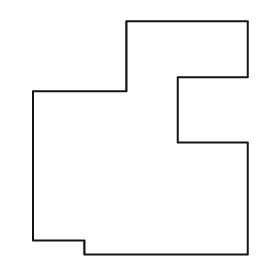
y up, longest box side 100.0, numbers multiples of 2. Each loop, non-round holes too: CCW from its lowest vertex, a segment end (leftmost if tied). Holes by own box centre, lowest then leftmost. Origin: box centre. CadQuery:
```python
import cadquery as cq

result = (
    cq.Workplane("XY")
    .moveTo(-24.0, -50.0)
    .lineTo(46.0, -50.0)
    .lineTo(46.0, -2.0)
    .lineTo(16.0, -2.0)
    .lineTo(16.0, 26.0)
    .lineTo(46.0, 26.0)
    .lineTo(46.0, 50.0)
    .lineTo(-6.0, 50.0)
    .lineTo(-6.0, 20.0)
    .lineTo(-46.0, 20.0)
    .lineTo(-46.0, -44.0)
    .lineTo(-24.0, -44.0)
    .close()
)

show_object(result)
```